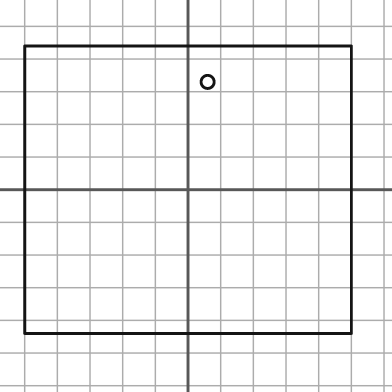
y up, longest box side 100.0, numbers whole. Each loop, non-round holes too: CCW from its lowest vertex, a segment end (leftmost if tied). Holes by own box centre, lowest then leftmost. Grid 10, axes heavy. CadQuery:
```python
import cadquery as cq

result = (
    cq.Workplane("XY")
    .moveTo(-50.0, -44.0)
    .lineTo(50.0, -44.0)
    .lineTo(50.0, 44.0)
    .lineTo(-50.0, 44.0)
    .close()
    .moveTo(6.0, 33.0)
    .circle(2.0)
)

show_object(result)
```